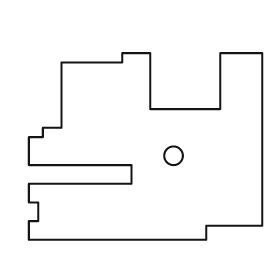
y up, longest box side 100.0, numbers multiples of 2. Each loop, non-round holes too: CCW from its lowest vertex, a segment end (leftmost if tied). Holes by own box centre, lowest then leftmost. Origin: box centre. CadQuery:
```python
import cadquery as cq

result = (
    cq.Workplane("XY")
    .moveTo(-50.0, -40.0)
    .lineTo(26.0, -40.0)
    .lineTo(26.0, -34.0)
    .lineTo(50.0, -34.0)
    .lineTo(50.0, 40.0)
    .lineTo(32.0, 40.0)
    .lineTo(32.0, 16.0)
    .lineTo(2.0, 16.0)
    .lineTo(2.0, 40.0)
    .lineTo(-10.0, 40.0)
    .lineTo(-10.0, 36.0)
    .lineTo(-36.0, 36.0)
    .lineTo(-36.0, 8.0)
    .lineTo(-44.0, 8.0)
    .lineTo(-44.0, 4.0)
    .lineTo(-50.0, 4.0)
    .lineTo(-50.0, -8.0)
    .lineTo(-6.0, -8.0)
    .lineTo(-6.0, -16.0)
    .lineTo(-50.0, -16.0)
    .lineTo(-50.0, -24.0)
    .lineTo(-46.0, -24.0)
    .lineTo(-46.0, -32.0)
    .lineTo(-50.0, -32.0)
    .close()
    .moveTo(12.0, -4.0)
    .circle(4.0)
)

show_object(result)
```